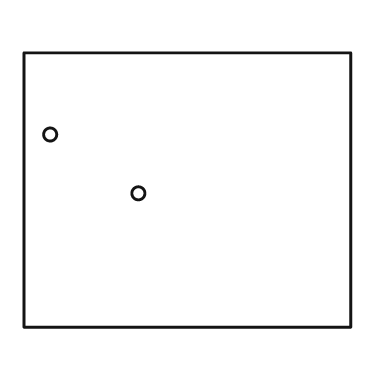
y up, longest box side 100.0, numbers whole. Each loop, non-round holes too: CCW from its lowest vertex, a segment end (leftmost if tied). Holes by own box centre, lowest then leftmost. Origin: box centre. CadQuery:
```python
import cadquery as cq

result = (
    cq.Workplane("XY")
    .moveTo(-50.0, -42.0)
    .lineTo(50.0, -42.0)
    .lineTo(50.0, 42.0)
    .lineTo(-50.0, 42.0)
    .close()
    .moveTo(-15.0, -1.0)
    .circle(2.0)
    .moveTo(-42.0, 17.0)
    .circle(2.0)
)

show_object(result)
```